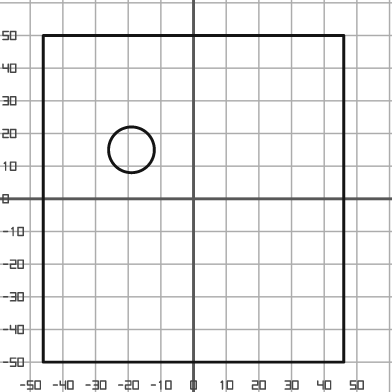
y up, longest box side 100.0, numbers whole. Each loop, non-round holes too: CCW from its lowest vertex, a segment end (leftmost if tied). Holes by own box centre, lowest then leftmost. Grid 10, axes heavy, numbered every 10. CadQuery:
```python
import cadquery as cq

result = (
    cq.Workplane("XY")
    .moveTo(-46.0, -50.0)
    .lineTo(46.0, -50.0)
    .lineTo(46.0, 50.0)
    .lineTo(-46.0, 50.0)
    .close()
    .moveTo(-19.0, 15.0)
    .circle(7.0)
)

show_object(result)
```